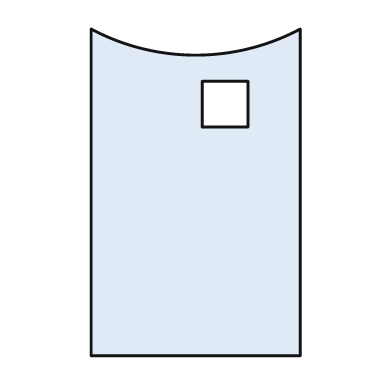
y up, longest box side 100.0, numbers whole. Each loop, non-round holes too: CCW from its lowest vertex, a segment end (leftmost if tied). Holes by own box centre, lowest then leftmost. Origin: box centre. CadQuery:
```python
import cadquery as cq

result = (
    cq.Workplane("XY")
    .moveTo(-32.0, -50.0)
    .lineTo(32.0, -50.0)
    .lineTo(32.0, 50.0)
    .threePointArc((0.0, 42.0), (-32.0, 50.0))
    .close()
    .moveTo(2.0, 20.0)
    .lineTo(16.0, 20.0)
    .lineTo(16.0, 34.0)
    .lineTo(2.0, 34.0)
    .close()
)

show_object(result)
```